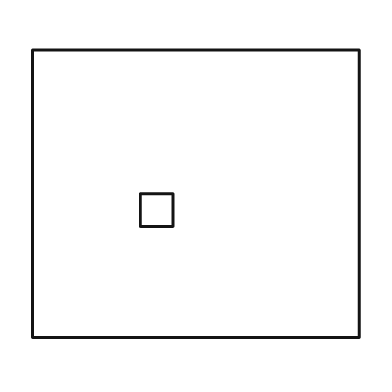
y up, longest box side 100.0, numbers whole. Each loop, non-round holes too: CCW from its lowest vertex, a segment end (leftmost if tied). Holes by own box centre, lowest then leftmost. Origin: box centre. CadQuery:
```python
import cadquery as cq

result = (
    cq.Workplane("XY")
    .moveTo(-50.0, -44.0)
    .lineTo(50.0, -44.0)
    .lineTo(50.0, 44.0)
    .lineTo(-50.0, 44.0)
    .close()
    .moveTo(-17.0, -10.0)
    .lineTo(-7.0, -10.0)
    .lineTo(-7.0, 0.0)
    .lineTo(-17.0, 0.0)
    .close()
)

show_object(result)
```